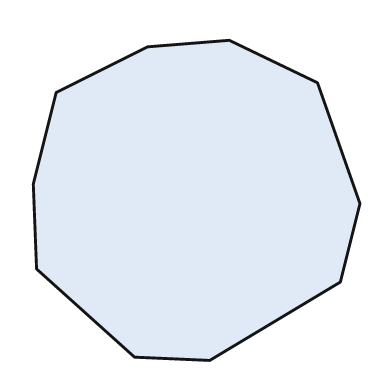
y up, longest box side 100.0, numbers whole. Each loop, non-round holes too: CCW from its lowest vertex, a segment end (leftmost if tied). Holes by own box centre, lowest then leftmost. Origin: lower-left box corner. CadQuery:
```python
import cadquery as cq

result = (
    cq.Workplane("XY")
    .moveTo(54.0, 0.0)
    .lineTo(94.0, 24.0)
    .lineTo(100.0, 48.0)
    .lineTo(87.0, 85.0)
    .lineTo(60.0, 98.0)
    .lineTo(35.0, 96.0)
    .lineTo(7.0, 82.0)
    .lineTo(0.0, 54.0)
    .lineTo(1.0, 28.0)
    .lineTo(31.0, 1.0)
    .close()
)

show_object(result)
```